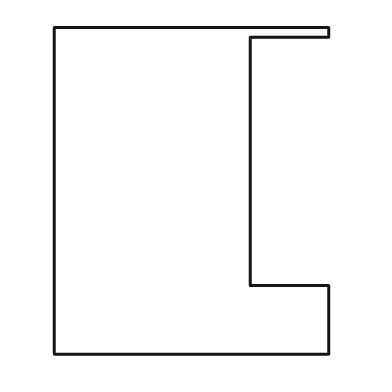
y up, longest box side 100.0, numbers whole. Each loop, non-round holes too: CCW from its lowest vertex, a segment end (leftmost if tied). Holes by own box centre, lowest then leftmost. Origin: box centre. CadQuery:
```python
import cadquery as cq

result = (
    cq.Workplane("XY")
    .moveTo(-42.0, -50.0)
    .lineTo(42.0, -50.0)
    .lineTo(42.0, -29.0)
    .lineTo(18.0, -29.0)
    .lineTo(18.0, 47.0)
    .lineTo(42.0, 47.0)
    .lineTo(42.0, 50.0)
    .lineTo(-42.0, 50.0)
    .close()
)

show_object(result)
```